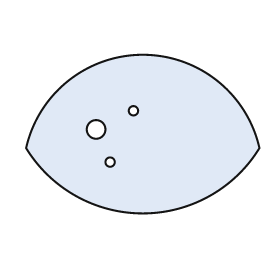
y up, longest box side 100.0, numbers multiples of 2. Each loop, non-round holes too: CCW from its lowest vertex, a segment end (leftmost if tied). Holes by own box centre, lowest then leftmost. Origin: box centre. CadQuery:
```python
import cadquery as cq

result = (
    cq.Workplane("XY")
    .moveTo(-50.0, -6.0)
    .threePointArc((0.0, -34.0), (50.0, -6.0))
    .threePointArc((0.0, 34.0), (-50.0, -6.0))
    .close()
    .moveTo(-14.0, -12.0)
    .circle(2.0)
    .moveTo(-20.0, 2.0)
    .circle(4.0)
    .moveTo(-4.0, 10.0)
    .circle(2.0)
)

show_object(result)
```